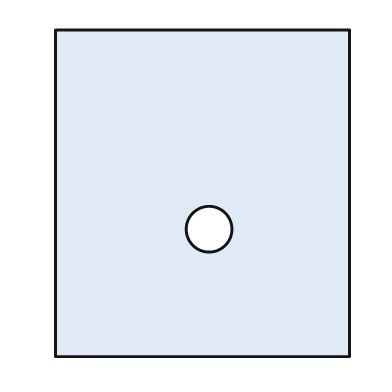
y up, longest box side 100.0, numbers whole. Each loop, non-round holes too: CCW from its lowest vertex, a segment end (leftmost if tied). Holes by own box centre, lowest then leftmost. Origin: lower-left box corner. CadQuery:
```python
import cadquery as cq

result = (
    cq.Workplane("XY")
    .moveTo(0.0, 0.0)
    .lineTo(90.0, 0.0)
    .lineTo(90.0, 100.0)
    .lineTo(0.0, 100.0)
    .close()
    .moveTo(47.0, 39.0)
    .circle(7.0)
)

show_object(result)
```